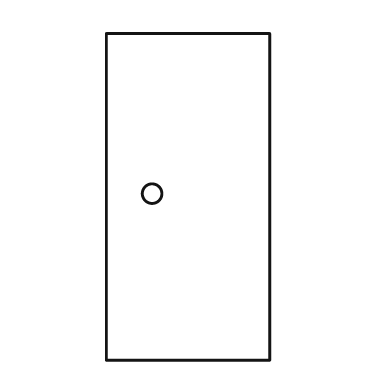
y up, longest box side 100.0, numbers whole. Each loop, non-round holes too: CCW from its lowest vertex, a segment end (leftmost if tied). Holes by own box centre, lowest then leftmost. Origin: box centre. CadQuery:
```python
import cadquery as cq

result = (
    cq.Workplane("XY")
    .moveTo(-25.0, -50.0)
    .lineTo(25.0, -50.0)
    .lineTo(25.0, 50.0)
    .lineTo(-25.0, 50.0)
    .close()
    .moveTo(-11.0, 1.0)
    .circle(3.0)
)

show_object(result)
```